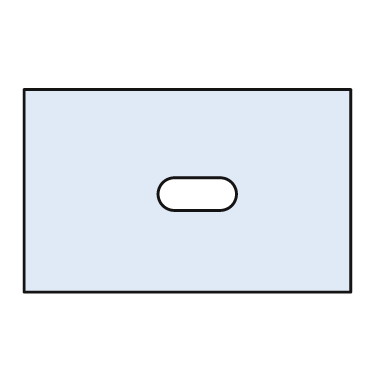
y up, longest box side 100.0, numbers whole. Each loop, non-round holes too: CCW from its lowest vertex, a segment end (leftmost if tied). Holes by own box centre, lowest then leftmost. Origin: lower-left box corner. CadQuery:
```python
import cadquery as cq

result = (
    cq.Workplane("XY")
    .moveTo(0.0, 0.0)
    .lineTo(100.0, 0.0)
    .lineTo(100.0, 62.0)
    .lineTo(0.0, 62.0)
    .close()
    .moveTo(46.0, 25.0)
    .lineTo(60.0, 25.0)
    .threePointArc((65.0, 30.0), (60.0, 35.0))
    .lineTo(46.0, 35.0)
    .threePointArc((41.0, 30.0), (46.0, 25.0))
    .close()
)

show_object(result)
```